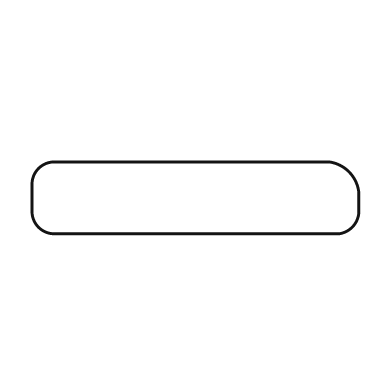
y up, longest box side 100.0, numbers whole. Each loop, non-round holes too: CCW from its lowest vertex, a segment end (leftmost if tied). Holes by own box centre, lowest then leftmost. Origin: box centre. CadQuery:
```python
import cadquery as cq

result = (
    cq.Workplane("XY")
    .moveTo(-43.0, -11.0)
    .lineTo(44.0, -11.0)
    .threePointArc((48.0, -9.0), (50.0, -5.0))
    .lineTo(50.0, 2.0)
    .threePointArc((47.0, 8.0), (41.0, 11.0))
    .lineTo(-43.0, 11.0)
    .threePointArc((-48.0, 9.0), (-50.0, 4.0))
    .lineTo(-50.0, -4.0)
    .threePointArc((-48.0, -9.0), (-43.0, -11.0))
    .close()
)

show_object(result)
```